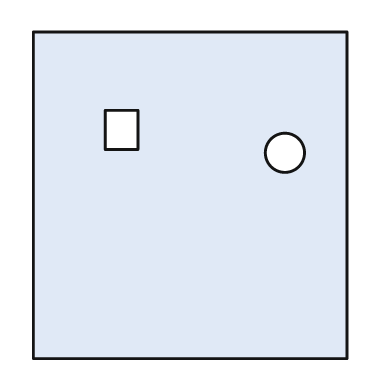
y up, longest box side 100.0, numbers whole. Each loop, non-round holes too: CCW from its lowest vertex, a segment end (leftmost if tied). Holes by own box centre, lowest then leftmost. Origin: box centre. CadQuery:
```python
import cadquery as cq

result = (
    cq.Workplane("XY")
    .moveTo(-48.0, -50.0)
    .lineTo(48.0, -50.0)
    .lineTo(48.0, 50.0)
    .lineTo(-48.0, 50.0)
    .close()
    .moveTo(29.0, 13.0)
    .circle(6.0)
    .moveTo(-26.0, 14.0)
    .lineTo(-16.0, 14.0)
    .lineTo(-16.0, 26.0)
    .lineTo(-26.0, 26.0)
    .close()
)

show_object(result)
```